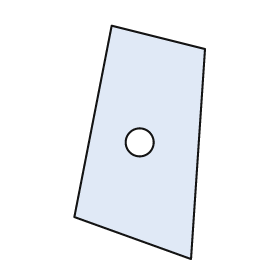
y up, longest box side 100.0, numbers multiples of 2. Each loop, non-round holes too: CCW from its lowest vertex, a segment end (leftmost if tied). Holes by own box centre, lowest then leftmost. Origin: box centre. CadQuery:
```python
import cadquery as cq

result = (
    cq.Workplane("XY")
    .moveTo(22.0, -50.0)
    .lineTo(28.0, 40.0)
    .lineTo(-12.0, 50.0)
    .lineTo(-28.0, -32.0)
    .close()
    .moveTo(0.0, 0.0)
    .circle(6.0)
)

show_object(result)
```